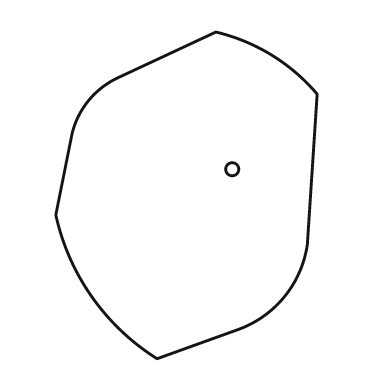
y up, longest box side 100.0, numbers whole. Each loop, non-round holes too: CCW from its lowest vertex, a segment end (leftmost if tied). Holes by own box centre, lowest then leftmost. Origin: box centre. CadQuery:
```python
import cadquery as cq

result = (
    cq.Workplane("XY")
    .moveTo(-9.0, -50.0)
    .lineTo(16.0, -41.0)
    .threePointArc((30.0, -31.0), (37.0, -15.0))
    .lineTo(40.0, 31.0)
    .threePointArc((26.0, 43.0), (9.0, 50.0))
    .lineTo(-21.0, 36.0)
    .threePointArc((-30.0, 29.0), (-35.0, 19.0))
    .lineTo(-40.0, -6.0)
    .threePointArc((-29.0, -31.0), (-9.0, -50.0))
    .close()
    .moveTo(14.0, 8.0)
    .circle(2.0)
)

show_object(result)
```